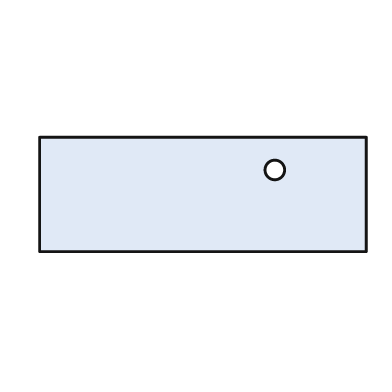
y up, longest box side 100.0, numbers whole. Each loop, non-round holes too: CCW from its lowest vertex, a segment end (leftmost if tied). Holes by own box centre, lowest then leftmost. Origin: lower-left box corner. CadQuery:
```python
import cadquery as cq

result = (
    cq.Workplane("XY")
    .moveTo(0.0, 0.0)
    .lineTo(100.0, 0.0)
    .lineTo(100.0, 35.0)
    .lineTo(0.0, 35.0)
    .close()
    .moveTo(72.0, 25.0)
    .circle(3.0)
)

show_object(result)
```